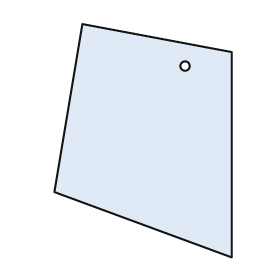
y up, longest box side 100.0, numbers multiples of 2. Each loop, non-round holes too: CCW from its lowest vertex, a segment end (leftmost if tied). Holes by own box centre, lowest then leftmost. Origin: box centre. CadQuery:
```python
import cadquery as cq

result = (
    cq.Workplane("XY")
    .moveTo(38.0, -50.0)
    .lineTo(38.0, 38.0)
    .lineTo(-26.0, 50.0)
    .lineTo(-38.0, -22.0)
    .close()
    .moveTo(18.0, 32.0)
    .circle(2.0)
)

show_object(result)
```